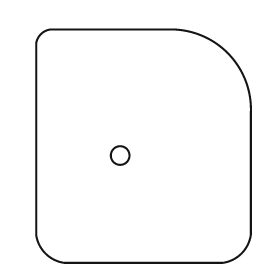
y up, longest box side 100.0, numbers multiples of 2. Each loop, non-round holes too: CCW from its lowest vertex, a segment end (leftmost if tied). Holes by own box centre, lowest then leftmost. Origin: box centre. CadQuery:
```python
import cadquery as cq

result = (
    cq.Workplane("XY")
    .moveTo(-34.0, -50.0)
    .lineTo(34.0, -50.0)
    .threePointArc((42.0, -46.0), (46.0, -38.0))
    .lineTo(46.0, 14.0)
    .threePointArc((36.0, 40.0), (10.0, 50.0))
    .lineTo(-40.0, 50.0)
    .threePointArc((-44.0, 48.0), (-46.0, 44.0))
    .lineTo(-46.0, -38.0)
    .threePointArc((-42.0, -46.0), (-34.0, -50.0))
    .close()
    .moveTo(-10.0, -4.0)
    .circle(4.0)
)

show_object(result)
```